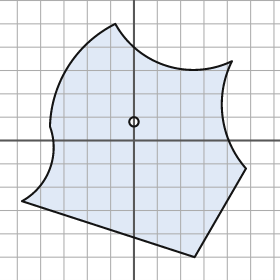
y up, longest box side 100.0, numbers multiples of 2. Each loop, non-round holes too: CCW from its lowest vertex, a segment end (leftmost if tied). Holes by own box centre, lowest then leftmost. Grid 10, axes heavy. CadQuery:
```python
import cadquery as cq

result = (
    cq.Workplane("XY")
    .moveTo(26.0, -50.0)
    .lineTo(48.0, -12.0)
    .threePointArc((38.0, 10.0), (42.0, 34.0))
    .threePointArc((14.0, 32.0), (-8.0, 50.0))
    .threePointArc((-28.0, 32.0), (-36.0, 6.0))
    .threePointArc((-36.0, -12.0), (-48.0, -26.0))
    .close()
    .moveTo(0.0, 8.0)
    .circle(2.0)
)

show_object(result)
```